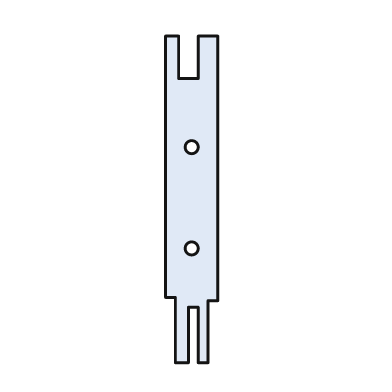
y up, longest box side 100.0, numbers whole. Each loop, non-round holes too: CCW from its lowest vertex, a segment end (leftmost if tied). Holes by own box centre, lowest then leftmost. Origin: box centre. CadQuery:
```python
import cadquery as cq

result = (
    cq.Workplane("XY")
    .moveTo(-5.0, -50.0)
    .lineTo(-1.0, -50.0)
    .lineTo(-1.0, -33.0)
    .lineTo(2.0, -33.0)
    .lineTo(2.0, -50.0)
    .lineTo(5.0, -50.0)
    .lineTo(5.0, -31.0)
    .lineTo(8.0, -31.0)
    .lineTo(8.0, 50.0)
    .lineTo(2.0, 50.0)
    .lineTo(2.0, 37.0)
    .lineTo(-4.0, 37.0)
    .lineTo(-4.0, 50.0)
    .lineTo(-8.0, 50.0)
    .lineTo(-8.0, -30.0)
    .lineTo(-5.0, -30.0)
    .close()
    .moveTo(0.0, -15.0)
    .circle(2.0)
    .moveTo(0.0, 16.0)
    .circle(2.0)
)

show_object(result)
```